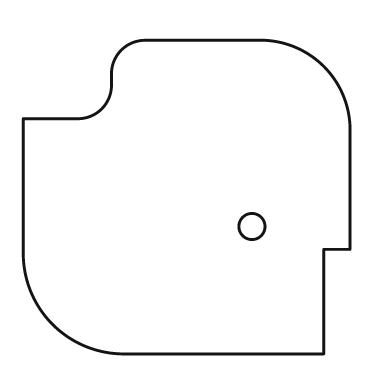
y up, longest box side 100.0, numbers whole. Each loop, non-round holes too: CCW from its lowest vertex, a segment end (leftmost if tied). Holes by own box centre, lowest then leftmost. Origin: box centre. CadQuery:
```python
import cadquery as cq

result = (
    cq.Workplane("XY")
    .moveTo(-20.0, -48.0)
    .lineTo(42.0, -48.0)
    .lineTo(42.0, -16.0)
    .lineTo(50.0, -16.0)
    .lineTo(50.0, 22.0)
    .threePointArc((42.0, 40.0), (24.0, 48.0))
    .lineTo(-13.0, 48.0)
    .threePointArc((-20.0, 45.0), (-23.0, 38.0))
    .lineTo(-23.0, 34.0)
    .threePointArc((-26.0, 27.0), (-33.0, 24.0))
    .lineTo(-50.0, 24.0)
    .lineTo(-50.0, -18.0)
    .threePointArc((-41.0, -39.0), (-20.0, -48.0))
    .close()
    .moveTo(20.0, -9.0)
    .circle(4.0)
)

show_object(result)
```